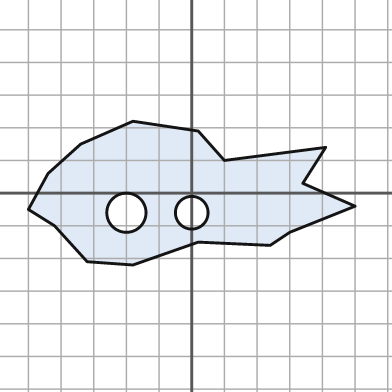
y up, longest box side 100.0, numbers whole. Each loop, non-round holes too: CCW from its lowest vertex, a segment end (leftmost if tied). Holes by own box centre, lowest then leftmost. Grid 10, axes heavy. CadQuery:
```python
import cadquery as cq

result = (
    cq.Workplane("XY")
    .moveTo(-18.0, -22.0)
    .lineTo(2.0, -15.0)
    .lineTo(24.0, -16.0)
    .lineTo(30.0, -12.0)
    .lineTo(50.0, -4.0)
    .lineTo(34.0, 3.0)
    .lineTo(41.0, 14.0)
    .lineTo(10.0, 10.0)
    .lineTo(2.0, 19.0)
    .lineTo(-18.0, 22.0)
    .lineTo(-34.0, 15.0)
    .lineTo(-44.0, 6.0)
    .lineTo(-50.0, -5.0)
    .lineTo(-42.0, -10.0)
    .lineTo(-32.0, -21.0)
    .close()
    .moveTo(-20.0, -6.0)
    .circle(6.0)
    .moveTo(0.0, -6.0)
    .circle(5.0)
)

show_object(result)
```